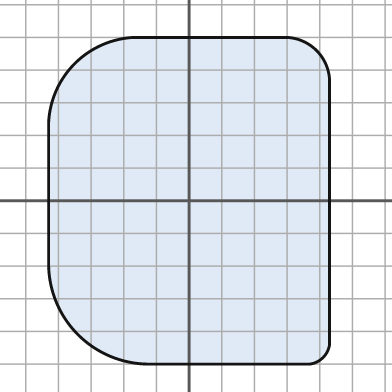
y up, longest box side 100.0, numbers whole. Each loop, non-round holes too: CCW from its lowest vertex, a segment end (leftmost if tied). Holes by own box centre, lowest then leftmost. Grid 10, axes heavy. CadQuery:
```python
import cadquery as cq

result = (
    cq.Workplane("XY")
    .moveTo(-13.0, -50.0)
    .lineTo(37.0, -50.0)
    .threePointArc((41.0, -48.0), (43.0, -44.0))
    .lineTo(43.0, 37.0)
    .threePointArc((39.0, 46.0), (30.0, 50.0))
    .lineTo(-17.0, 50.0)
    .threePointArc((-35.0, 42.0), (-43.0, 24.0))
    .lineTo(-43.0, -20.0)
    .threePointArc((-34.0, -41.0), (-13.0, -50.0))
    .close()
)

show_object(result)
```